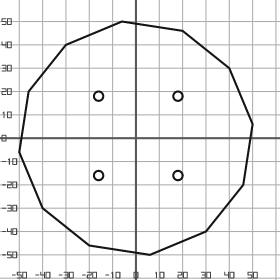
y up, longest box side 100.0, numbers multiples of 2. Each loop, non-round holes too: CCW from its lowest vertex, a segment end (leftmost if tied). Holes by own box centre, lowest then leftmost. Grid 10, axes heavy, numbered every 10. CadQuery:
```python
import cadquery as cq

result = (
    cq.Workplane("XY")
    .moveTo(6.0, -50.0)
    .lineTo(30.0, -40.0)
    .lineTo(46.0, -20.0)
    .lineTo(50.0, 6.0)
    .lineTo(40.0, 30.0)
    .lineTo(20.0, 46.0)
    .lineTo(-6.0, 50.0)
    .lineTo(-30.0, 40.0)
    .lineTo(-46.0, 20.0)
    .lineTo(-50.0, -6.0)
    .lineTo(-40.0, -30.0)
    .lineTo(-20.0, -46.0)
    .close()
    .moveTo(-16.0, -16.0)
    .circle(2.0)
    .moveTo(18.0, -16.0)
    .circle(2.0)
    .moveTo(-16.0, 18.0)
    .circle(2.0)
    .moveTo(18.0, 18.0)
    .circle(2.0)
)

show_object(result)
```